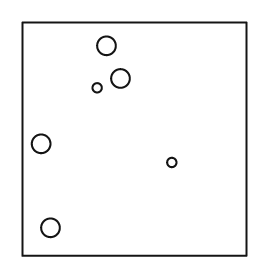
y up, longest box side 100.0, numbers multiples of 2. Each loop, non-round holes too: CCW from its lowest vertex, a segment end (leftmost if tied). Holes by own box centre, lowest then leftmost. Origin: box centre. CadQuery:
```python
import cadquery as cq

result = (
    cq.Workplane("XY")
    .moveTo(-48.0, -50.0)
    .lineTo(48.0, -50.0)
    .lineTo(48.0, 50.0)
    .lineTo(-48.0, 50.0)
    .close()
    .moveTo(-36.0, -38.0)
    .circle(4.0)
    .moveTo(16.0, -10.0)
    .circle(2.0)
    .moveTo(-40.0, -2.0)
    .circle(4.0)
    .moveTo(-16.0, 22.0)
    .circle(2.0)
    .moveTo(-6.0, 26.0)
    .circle(4.0)
    .moveTo(-12.0, 40.0)
    .circle(4.0)
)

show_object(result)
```